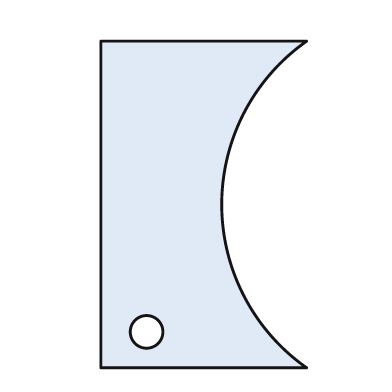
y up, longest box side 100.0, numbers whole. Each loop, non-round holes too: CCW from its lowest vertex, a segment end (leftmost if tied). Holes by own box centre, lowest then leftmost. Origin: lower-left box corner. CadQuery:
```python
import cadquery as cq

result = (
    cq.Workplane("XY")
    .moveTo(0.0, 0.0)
    .lineTo(63.0, 0.0)
    .threePointArc((37.0, 50.0), (63.0, 100.0))
    .lineTo(0.0, 100.0)
    .close()
    .moveTo(14.0, 11.0)
    .circle(5.0)
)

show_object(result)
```